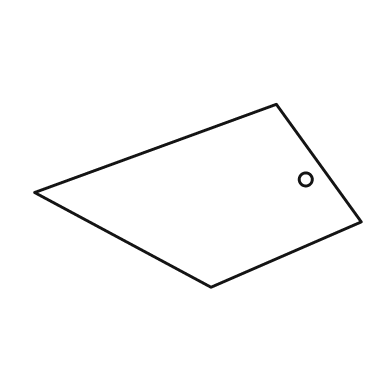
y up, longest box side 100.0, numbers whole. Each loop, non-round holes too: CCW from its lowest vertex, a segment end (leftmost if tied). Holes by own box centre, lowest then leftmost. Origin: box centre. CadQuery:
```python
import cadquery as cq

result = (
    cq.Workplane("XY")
    .moveTo(4.0, -28.0)
    .lineTo(50.0, -8.0)
    .lineTo(24.0, 28.0)
    .lineTo(-50.0, 1.0)
    .close()
    .moveTo(33.0, 5.0)
    .circle(2.0)
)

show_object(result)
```